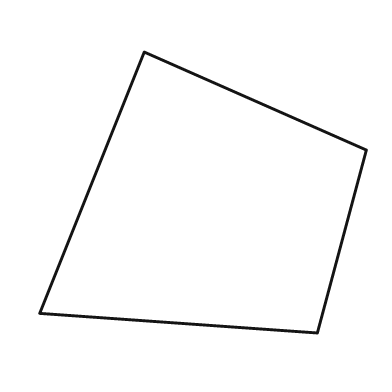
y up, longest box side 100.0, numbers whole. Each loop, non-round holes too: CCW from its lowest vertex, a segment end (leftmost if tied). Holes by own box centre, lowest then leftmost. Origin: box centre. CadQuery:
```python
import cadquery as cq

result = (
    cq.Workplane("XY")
    .moveTo(35.0, -43.0)
    .lineTo(50.0, 13.0)
    .lineTo(-18.0, 43.0)
    .lineTo(-50.0, -37.0)
    .close()
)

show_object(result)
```